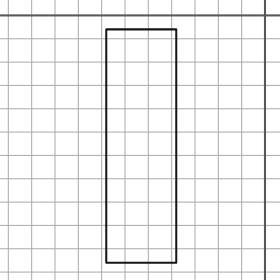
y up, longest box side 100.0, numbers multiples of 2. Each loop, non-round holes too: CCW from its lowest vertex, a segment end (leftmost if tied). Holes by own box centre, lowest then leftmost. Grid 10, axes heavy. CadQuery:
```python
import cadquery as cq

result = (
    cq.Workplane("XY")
    .moveTo(-68.0, -106.0)
    .lineTo(-38.0, -106.0)
    .lineTo(-38.0, -6.0)
    .lineTo(-68.0, -6.0)
    .close()
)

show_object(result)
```